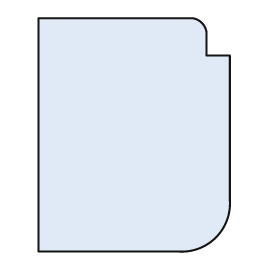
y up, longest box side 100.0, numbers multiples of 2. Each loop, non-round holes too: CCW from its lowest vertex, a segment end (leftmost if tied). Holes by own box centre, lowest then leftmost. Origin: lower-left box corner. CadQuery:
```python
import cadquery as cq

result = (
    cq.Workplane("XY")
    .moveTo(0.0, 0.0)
    .lineTo(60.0, 0.0)
    .threePointArc((76.0, 6.0), (82.0, 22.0))
    .lineTo(82.0, 84.0)
    .lineTo(72.0, 84.0)
    .lineTo(72.0, 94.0)
    .threePointArc((70.0, 98.0), (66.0, 100.0))
    .lineTo(0.0, 100.0)
    .close()
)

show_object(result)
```